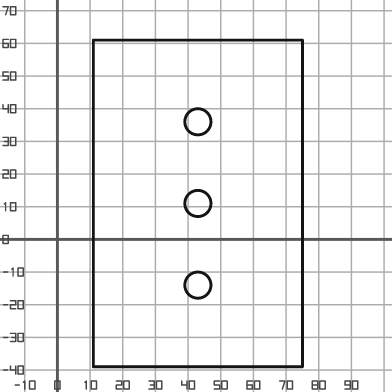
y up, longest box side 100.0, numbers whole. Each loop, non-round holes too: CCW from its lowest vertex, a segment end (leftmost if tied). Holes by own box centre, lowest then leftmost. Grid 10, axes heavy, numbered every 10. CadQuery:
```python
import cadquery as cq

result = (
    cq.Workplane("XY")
    .moveTo(11.0, -39.0)
    .lineTo(75.0, -39.0)
    .lineTo(75.0, 61.0)
    .lineTo(11.0, 61.0)
    .close()
    .moveTo(43.0, -14.0)
    .circle(4.0)
    .moveTo(43.0, 11.0)
    .circle(4.0)
    .moveTo(43.0, 36.0)
    .circle(4.0)
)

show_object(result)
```